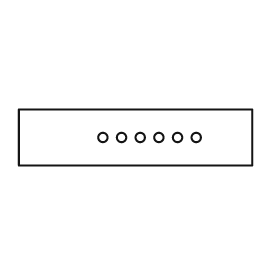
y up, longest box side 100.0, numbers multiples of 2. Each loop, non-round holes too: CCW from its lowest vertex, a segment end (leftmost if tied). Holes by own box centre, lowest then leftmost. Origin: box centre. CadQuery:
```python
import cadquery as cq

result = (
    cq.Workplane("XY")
    .moveTo(-50.0, -12.0)
    .lineTo(50.0, -12.0)
    .lineTo(50.0, 12.0)
    .lineTo(-50.0, 12.0)
    .close()
    .moveTo(-14.0, 0.0)
    .circle(2.0)
    .moveTo(-6.0, 0.0)
    .circle(2.0)
    .moveTo(2.0, 0.0)
    .circle(2.0)
    .moveTo(10.0, 0.0)
    .circle(2.0)
    .moveTo(18.0, 0.0)
    .circle(2.0)
    .moveTo(26.0, 0.0)
    .circle(2.0)
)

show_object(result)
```